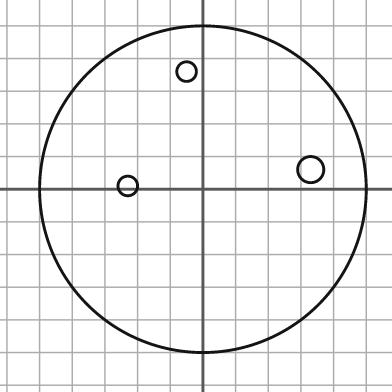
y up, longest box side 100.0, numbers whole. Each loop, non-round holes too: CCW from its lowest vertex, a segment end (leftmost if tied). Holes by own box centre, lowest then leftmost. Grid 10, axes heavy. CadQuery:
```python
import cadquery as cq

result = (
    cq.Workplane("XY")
    .moveTo(0.0, 0.0)
    .circle(50.0)
    .moveTo(-23.0, 1.0)
    .circle(3.0)
    .moveTo(33.0, 6.0)
    .circle(4.0)
    .moveTo(-5.0, 36.0)
    .circle(3.0)
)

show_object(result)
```